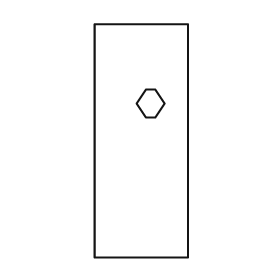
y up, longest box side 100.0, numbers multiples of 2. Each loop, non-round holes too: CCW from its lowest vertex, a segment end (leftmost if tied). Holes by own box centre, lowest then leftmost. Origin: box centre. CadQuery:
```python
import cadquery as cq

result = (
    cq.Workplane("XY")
    .moveTo(-20.0, -50.0)
    .lineTo(20.0, -50.0)
    .lineTo(20.0, 50.0)
    .lineTo(-20.0, 50.0)
    .close()
    .moveTo(2.0, 10.0)
    .lineTo(6.0, 10.0)
    .lineTo(10.0, 16.0)
    .lineTo(6.0, 22.0)
    .lineTo(2.0, 22.0)
    .lineTo(-2.0, 16.0)
    .close()
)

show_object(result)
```